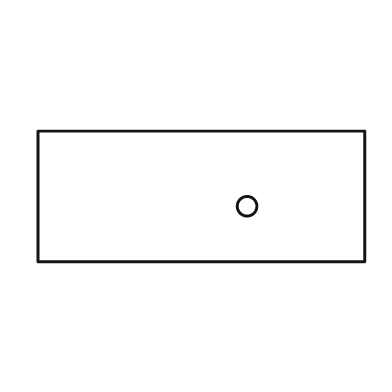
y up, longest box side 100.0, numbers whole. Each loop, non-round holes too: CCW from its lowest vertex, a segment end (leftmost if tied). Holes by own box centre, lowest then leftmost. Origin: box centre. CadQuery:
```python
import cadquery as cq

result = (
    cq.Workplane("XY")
    .moveTo(-50.0, -20.0)
    .lineTo(50.0, -20.0)
    .lineTo(50.0, 20.0)
    .lineTo(-50.0, 20.0)
    .close()
    .moveTo(14.0, -3.0)
    .circle(3.0)
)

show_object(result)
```